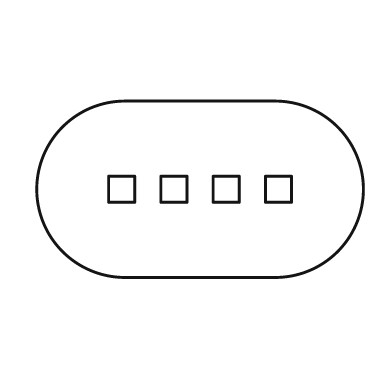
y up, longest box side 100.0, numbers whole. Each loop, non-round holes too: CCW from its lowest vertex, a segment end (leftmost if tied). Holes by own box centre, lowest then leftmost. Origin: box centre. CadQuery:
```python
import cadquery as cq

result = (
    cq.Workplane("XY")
    .moveTo(-23.0, -27.0)
    .lineTo(23.0, -27.0)
    .threePointArc((50.0, 0.0), (23.0, 27.0))
    .lineTo(-23.0, 27.0)
    .threePointArc((-50.0, 0.0), (-23.0, -27.0))
    .close()
    .moveTo(-28.0, -4.0)
    .lineTo(-20.0, -4.0)
    .lineTo(-20.0, 4.0)
    .lineTo(-28.0, 4.0)
    .close()
    .moveTo(-12.0, -4.0)
    .lineTo(-4.0, -4.0)
    .lineTo(-4.0, 4.0)
    .lineTo(-12.0, 4.0)
    .close()
    .moveTo(4.0, -4.0)
    .lineTo(12.0, -4.0)
    .lineTo(12.0, 4.0)
    .lineTo(4.0, 4.0)
    .close()
    .moveTo(20.0, -4.0)
    .lineTo(28.0, -4.0)
    .lineTo(28.0, 4.0)
    .lineTo(20.0, 4.0)
    .close()
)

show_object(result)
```